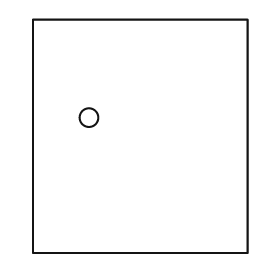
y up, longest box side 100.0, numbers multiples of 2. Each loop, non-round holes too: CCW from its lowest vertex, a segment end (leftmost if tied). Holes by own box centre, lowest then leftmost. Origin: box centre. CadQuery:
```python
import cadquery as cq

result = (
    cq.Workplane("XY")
    .moveTo(-46.0, -50.0)
    .lineTo(46.0, -50.0)
    .lineTo(46.0, 50.0)
    .lineTo(-46.0, 50.0)
    .close()
    .moveTo(-22.0, 8.0)
    .circle(4.0)
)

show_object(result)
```